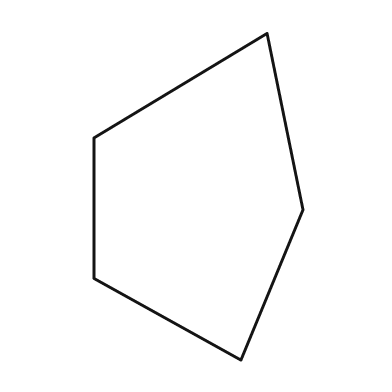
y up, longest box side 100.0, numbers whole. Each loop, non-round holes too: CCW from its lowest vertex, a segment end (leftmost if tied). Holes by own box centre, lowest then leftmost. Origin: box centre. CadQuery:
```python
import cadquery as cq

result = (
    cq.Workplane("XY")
    .moveTo(13.0, -50.0)
    .lineTo(32.0, -4.0)
    .lineTo(21.0, 50.0)
    .lineTo(-32.0, 18.0)
    .lineTo(-32.0, -25.0)
    .close()
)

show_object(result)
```